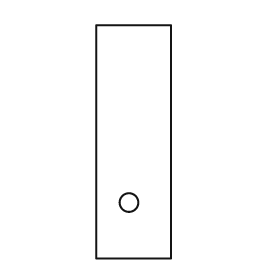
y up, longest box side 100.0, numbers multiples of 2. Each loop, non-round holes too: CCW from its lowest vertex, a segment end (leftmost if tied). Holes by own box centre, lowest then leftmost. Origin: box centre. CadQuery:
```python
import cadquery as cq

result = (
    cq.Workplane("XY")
    .moveTo(-16.0, -50.0)
    .lineTo(16.0, -50.0)
    .lineTo(16.0, 50.0)
    .lineTo(-16.0, 50.0)
    .close()
    .moveTo(-2.0, -26.0)
    .circle(4.0)
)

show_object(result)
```